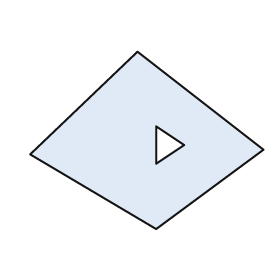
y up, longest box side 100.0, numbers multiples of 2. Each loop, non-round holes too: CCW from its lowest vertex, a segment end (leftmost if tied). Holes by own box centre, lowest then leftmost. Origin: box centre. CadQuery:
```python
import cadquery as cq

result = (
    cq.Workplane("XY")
    .moveTo(4.0, -38.0)
    .lineTo(50.0, -4.0)
    .lineTo(-4.0, 38.0)
    .lineTo(-50.0, -6.0)
    .close()
    .moveTo(4.0, -10.0)
    .lineTo(16.0, -2.0)
    .lineTo(4.0, 6.0)
    .close()
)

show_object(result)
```